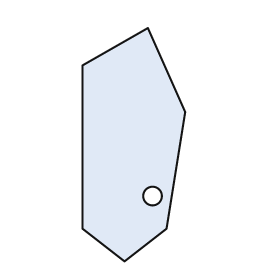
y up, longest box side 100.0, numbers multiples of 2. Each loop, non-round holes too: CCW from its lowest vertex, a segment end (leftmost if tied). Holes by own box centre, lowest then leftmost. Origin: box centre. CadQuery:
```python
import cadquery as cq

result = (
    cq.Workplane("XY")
    .moveTo(-4.0, -50.0)
    .lineTo(14.0, -36.0)
    .lineTo(22.0, 14.0)
    .lineTo(6.0, 50.0)
    .lineTo(-22.0, 34.0)
    .lineTo(-22.0, -36.0)
    .close()
    .moveTo(8.0, -22.0)
    .circle(4.0)
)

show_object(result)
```